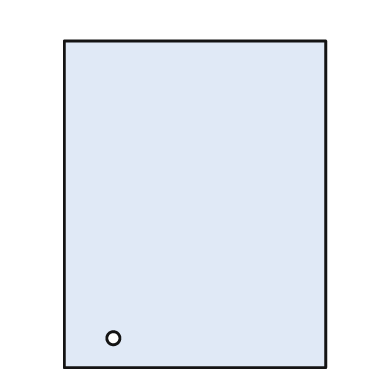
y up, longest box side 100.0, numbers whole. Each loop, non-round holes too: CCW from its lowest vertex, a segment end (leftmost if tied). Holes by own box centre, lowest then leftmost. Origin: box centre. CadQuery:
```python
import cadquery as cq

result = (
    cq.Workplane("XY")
    .moveTo(-40.0, -50.0)
    .lineTo(40.0, -50.0)
    .lineTo(40.0, 50.0)
    .lineTo(-40.0, 50.0)
    .close()
    .moveTo(-25.0, -41.0)
    .circle(2.0)
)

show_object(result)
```